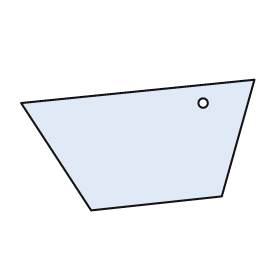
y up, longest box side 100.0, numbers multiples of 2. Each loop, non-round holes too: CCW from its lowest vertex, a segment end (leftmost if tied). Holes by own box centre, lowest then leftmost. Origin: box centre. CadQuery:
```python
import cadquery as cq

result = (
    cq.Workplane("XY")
    .moveTo(-20.0, -28.0)
    .lineTo(36.0, -22.0)
    .lineTo(50.0, 28.0)
    .lineTo(-50.0, 18.0)
    .close()
    .moveTo(28.0, 18.0)
    .circle(2.0)
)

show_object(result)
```